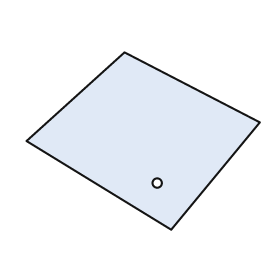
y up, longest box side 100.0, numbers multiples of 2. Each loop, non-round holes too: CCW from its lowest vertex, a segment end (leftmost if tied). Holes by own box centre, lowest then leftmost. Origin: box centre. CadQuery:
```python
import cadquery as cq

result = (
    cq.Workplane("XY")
    .moveTo(12.0, -38.0)
    .lineTo(50.0, 8.0)
    .lineTo(-8.0, 38.0)
    .lineTo(-50.0, 0.0)
    .close()
    .moveTo(6.0, -18.0)
    .circle(2.0)
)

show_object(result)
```